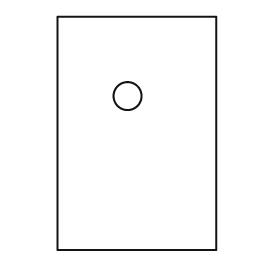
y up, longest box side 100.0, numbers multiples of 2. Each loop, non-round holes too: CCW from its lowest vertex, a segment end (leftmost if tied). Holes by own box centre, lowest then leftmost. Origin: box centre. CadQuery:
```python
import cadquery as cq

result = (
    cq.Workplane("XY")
    .moveTo(-34.0, -50.0)
    .lineTo(34.0, -50.0)
    .lineTo(34.0, 50.0)
    .lineTo(-34.0, 50.0)
    .close()
    .moveTo(-4.0, 16.0)
    .circle(6.0)
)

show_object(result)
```